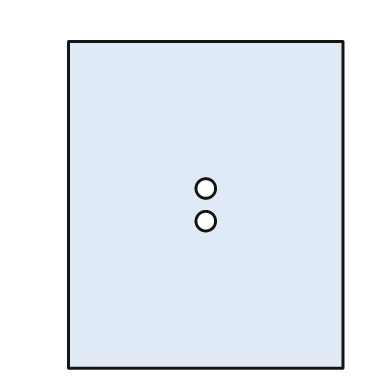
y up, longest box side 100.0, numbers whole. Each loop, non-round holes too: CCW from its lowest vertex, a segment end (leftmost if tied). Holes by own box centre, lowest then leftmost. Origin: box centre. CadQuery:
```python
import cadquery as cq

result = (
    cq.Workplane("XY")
    .moveTo(-42.0, -50.0)
    .lineTo(42.0, -50.0)
    .lineTo(42.0, 50.0)
    .lineTo(-42.0, 50.0)
    .close()
    .moveTo(0.0, -5.0)
    .circle(3.0)
    .moveTo(0.0, 5.0)
    .circle(3.0)
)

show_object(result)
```